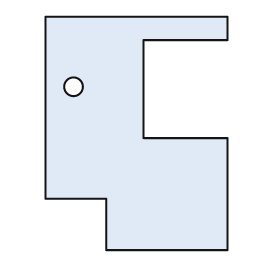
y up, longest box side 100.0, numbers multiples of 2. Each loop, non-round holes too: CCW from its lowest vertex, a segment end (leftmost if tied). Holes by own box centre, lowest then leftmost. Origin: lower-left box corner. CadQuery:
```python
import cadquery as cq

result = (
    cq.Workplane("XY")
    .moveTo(26.0, 0.0)
    .lineTo(78.0, 0.0)
    .lineTo(78.0, 48.0)
    .lineTo(42.0, 48.0)
    .lineTo(42.0, 90.0)
    .lineTo(78.0, 90.0)
    .lineTo(78.0, 100.0)
    .lineTo(0.0, 100.0)
    .lineTo(0.0, 22.0)
    .lineTo(26.0, 22.0)
    .close()
    .moveTo(12.0, 70.0)
    .circle(4.0)
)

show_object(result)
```